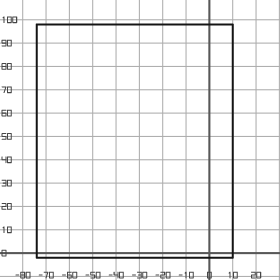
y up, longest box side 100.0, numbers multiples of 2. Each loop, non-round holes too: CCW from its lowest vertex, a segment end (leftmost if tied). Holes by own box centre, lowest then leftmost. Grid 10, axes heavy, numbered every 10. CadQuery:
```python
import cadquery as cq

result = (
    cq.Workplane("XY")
    .moveTo(-74.0, -2.0)
    .lineTo(10.0, -2.0)
    .lineTo(10.0, 98.0)
    .lineTo(-74.0, 98.0)
    .close()
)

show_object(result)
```